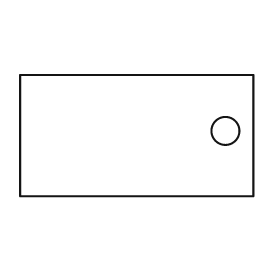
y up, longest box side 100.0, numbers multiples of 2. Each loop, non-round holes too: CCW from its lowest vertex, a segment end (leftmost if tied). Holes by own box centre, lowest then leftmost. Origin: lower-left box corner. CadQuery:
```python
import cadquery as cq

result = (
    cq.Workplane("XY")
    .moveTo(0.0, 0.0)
    .lineTo(100.0, 0.0)
    .lineTo(100.0, 52.0)
    .lineTo(0.0, 52.0)
    .close()
    .moveTo(88.0, 28.0)
    .circle(6.0)
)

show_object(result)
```